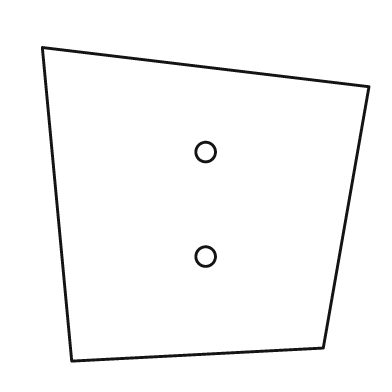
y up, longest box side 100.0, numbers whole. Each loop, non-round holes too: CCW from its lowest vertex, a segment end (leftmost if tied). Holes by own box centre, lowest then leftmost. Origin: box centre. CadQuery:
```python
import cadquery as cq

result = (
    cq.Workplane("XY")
    .moveTo(-41.0, -48.0)
    .lineTo(36.0, -44.0)
    .lineTo(50.0, 36.0)
    .lineTo(-50.0, 48.0)
    .close()
    .moveTo(0.0, -16.0)
    .circle(3.0)
    .moveTo(0.0, 16.0)
    .circle(3.0)
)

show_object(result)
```